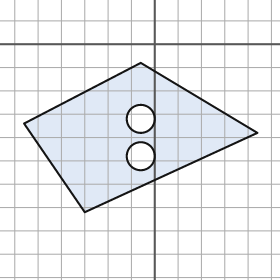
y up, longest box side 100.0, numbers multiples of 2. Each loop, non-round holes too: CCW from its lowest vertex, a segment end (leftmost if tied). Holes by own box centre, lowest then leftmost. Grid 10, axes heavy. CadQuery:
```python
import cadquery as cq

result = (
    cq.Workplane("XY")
    .moveTo(-30.0, -72.0)
    .lineTo(44.0, -38.0)
    .lineTo(-6.0, -8.0)
    .lineTo(-56.0, -34.0)
    .close()
    .moveTo(-6.0, -48.0)
    .circle(6.0)
    .moveTo(-6.0, -32.0)
    .circle(6.0)
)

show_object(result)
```